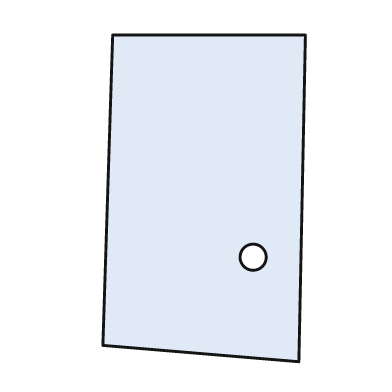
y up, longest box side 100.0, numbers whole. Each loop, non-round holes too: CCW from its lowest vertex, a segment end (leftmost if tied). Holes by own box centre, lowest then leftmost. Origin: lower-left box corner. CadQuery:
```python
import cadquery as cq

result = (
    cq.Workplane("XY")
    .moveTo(60.0, 0.0)
    .lineTo(62.0, 100.0)
    .lineTo(3.0, 100.0)
    .lineTo(0.0, 5.0)
    .close()
    .moveTo(46.0, 32.0)
    .circle(4.0)
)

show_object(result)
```